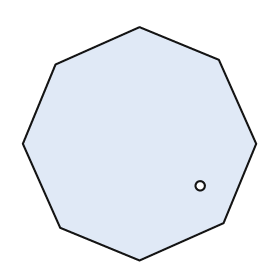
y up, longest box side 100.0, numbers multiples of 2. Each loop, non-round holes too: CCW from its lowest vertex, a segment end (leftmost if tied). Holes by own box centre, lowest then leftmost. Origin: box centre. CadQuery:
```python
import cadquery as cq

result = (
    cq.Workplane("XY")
    .moveTo(0.0, -50.0)
    .lineTo(36.0, -34.0)
    .lineTo(50.0, 0.0)
    .lineTo(34.0, 36.0)
    .lineTo(0.0, 50.0)
    .lineTo(-36.0, 34.0)
    .lineTo(-50.0, 0.0)
    .lineTo(-34.0, -36.0)
    .close()
    .moveTo(26.0, -18.0)
    .circle(2.0)
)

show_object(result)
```